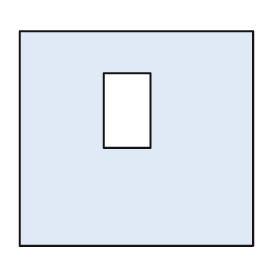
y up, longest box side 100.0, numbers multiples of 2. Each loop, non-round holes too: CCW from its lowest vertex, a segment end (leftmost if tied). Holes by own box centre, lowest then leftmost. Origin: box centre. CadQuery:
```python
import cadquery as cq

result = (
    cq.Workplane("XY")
    .moveTo(-50.0, -46.0)
    .lineTo(50.0, -46.0)
    .lineTo(50.0, 46.0)
    .lineTo(-50.0, 46.0)
    .close()
    .moveTo(-14.0, -4.0)
    .lineTo(6.0, -4.0)
    .lineTo(6.0, 28.0)
    .lineTo(-14.0, 28.0)
    .close()
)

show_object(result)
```